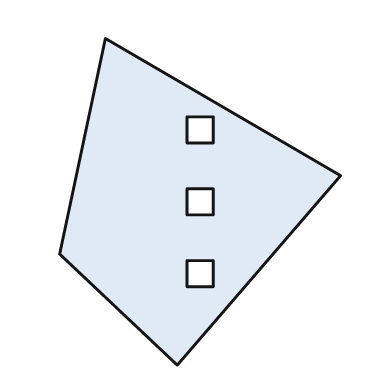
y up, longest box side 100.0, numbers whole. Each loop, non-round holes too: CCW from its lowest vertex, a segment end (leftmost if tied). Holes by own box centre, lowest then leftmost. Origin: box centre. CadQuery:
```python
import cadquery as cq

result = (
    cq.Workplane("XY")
    .moveTo(-7.0, -50.0)
    .lineTo(43.0, 8.0)
    .lineTo(-29.0, 50.0)
    .lineTo(-43.0, -16.0)
    .close()
    .moveTo(-4.0, -26.0)
    .lineTo(4.0, -26.0)
    .lineTo(4.0, -18.0)
    .lineTo(-4.0, -18.0)
    .close()
    .moveTo(-4.0, -4.0)
    .lineTo(4.0, -4.0)
    .lineTo(4.0, 4.0)
    .lineTo(-4.0, 4.0)
    .close()
    .moveTo(-4.0, 18.0)
    .lineTo(4.0, 18.0)
    .lineTo(4.0, 26.0)
    .lineTo(-4.0, 26.0)
    .close()
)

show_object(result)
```